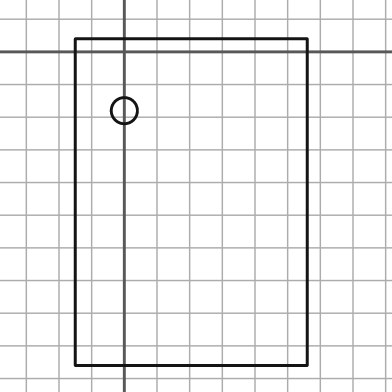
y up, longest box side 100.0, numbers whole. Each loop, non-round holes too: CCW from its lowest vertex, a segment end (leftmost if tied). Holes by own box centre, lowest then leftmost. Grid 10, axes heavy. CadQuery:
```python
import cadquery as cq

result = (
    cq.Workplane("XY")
    .moveTo(-15.0, -96.0)
    .lineTo(56.0, -96.0)
    .lineTo(56.0, 4.0)
    .lineTo(-15.0, 4.0)
    .close()
    .moveTo(0.0, -18.0)
    .circle(4.0)
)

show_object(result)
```